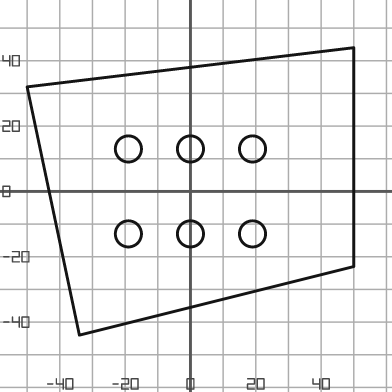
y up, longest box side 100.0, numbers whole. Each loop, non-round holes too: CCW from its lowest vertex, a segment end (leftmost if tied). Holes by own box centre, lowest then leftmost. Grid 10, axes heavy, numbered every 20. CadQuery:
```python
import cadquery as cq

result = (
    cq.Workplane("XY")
    .moveTo(-34.0, -44.0)
    .lineTo(50.0, -23.0)
    .lineTo(50.0, 44.0)
    .lineTo(-50.0, 32.0)
    .close()
    .moveTo(-19.0, -13.0)
    .circle(4.0)
    .moveTo(0.0, -13.0)
    .circle(4.0)
    .moveTo(19.0, -13.0)
    .circle(4.0)
    .moveTo(-19.0, 13.0)
    .circle(4.0)
    .moveTo(0.0, 13.0)
    .circle(4.0)
    .moveTo(19.0, 13.0)
    .circle(4.0)
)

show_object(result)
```